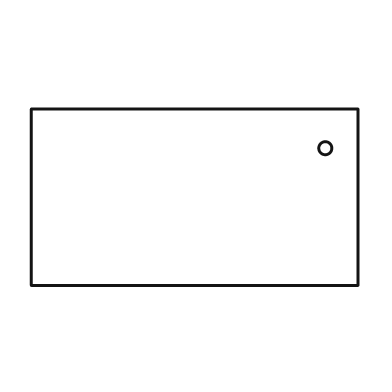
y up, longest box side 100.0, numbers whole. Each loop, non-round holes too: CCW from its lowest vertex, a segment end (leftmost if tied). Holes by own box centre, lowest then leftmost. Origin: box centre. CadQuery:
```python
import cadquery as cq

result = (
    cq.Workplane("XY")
    .moveTo(-50.0, -27.0)
    .lineTo(50.0, -27.0)
    .lineTo(50.0, 27.0)
    .lineTo(-50.0, 27.0)
    .close()
    .moveTo(40.0, 15.0)
    .circle(2.0)
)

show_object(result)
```